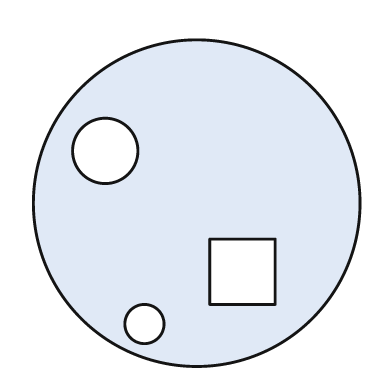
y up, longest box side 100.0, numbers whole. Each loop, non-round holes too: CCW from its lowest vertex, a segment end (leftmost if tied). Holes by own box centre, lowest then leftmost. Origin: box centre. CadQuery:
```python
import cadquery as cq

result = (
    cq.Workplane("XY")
    .moveTo(0.0, 0.0)
    .circle(50.0)
    .moveTo(-16.0, -37.0)
    .circle(6.0)
    .moveTo(4.0, -31.0)
    .lineTo(24.0, -31.0)
    .lineTo(24.0, -11.0)
    .lineTo(4.0, -11.0)
    .close()
    .moveTo(-28.0, 16.0)
    .circle(10.0)
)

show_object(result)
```